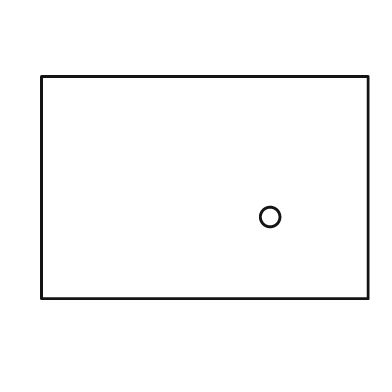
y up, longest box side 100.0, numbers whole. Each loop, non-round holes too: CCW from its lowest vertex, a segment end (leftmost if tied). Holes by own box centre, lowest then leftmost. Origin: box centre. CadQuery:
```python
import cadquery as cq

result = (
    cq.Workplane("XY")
    .moveTo(-50.0, -34.0)
    .lineTo(50.0, -34.0)
    .lineTo(50.0, 34.0)
    .lineTo(-50.0, 34.0)
    .close()
    .moveTo(20.0, -9.0)
    .circle(3.0)
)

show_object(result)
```